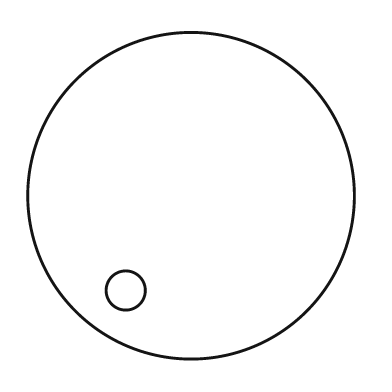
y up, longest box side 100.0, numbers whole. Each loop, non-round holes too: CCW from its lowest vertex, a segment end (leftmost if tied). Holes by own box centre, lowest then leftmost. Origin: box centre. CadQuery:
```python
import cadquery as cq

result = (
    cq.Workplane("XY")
    .moveTo(0.0, 0.0)
    .circle(50.0)
    .moveTo(-20.0, -29.0)
    .circle(6.0)
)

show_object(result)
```